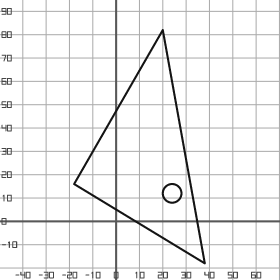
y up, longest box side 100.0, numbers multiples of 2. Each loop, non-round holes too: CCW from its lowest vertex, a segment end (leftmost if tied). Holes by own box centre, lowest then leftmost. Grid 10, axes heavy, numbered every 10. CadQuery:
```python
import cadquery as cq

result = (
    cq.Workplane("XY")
    .moveTo(38.0, -18.0)
    .lineTo(20.0, 82.0)
    .lineTo(-18.0, 16.0)
    .close()
    .moveTo(24.0, 12.0)
    .circle(4.0)
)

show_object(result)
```